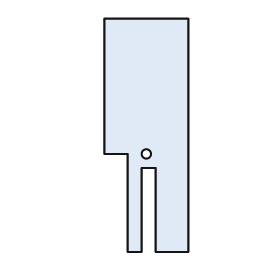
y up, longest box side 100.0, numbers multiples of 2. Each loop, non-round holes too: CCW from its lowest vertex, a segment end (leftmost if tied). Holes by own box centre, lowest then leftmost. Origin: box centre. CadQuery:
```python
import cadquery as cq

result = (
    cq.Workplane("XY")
    .moveTo(-8.0, -50.0)
    .lineTo(-2.0, -50.0)
    .lineTo(-2.0, -14.0)
    .lineTo(4.0, -14.0)
    .lineTo(4.0, -50.0)
    .lineTo(18.0, -50.0)
    .lineTo(18.0, 50.0)
    .lineTo(-18.0, 50.0)
    .lineTo(-18.0, -8.0)
    .lineTo(-8.0, -8.0)
    .close()
    .moveTo(0.0, -8.0)
    .circle(2.0)
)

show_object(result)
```